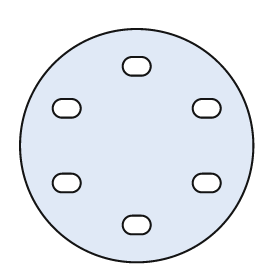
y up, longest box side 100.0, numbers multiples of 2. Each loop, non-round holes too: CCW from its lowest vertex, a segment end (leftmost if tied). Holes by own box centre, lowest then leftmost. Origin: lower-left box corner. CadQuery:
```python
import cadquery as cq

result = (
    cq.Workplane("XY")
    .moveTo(50.0, 50.0)
    .circle(50.0)
    .moveTo(48.0, 12.0)
    .lineTo(52.0, 12.0)
    .threePointArc((56.0, 16.0), (52.0, 20.0))
    .lineTo(48.0, 20.0)
    .threePointArc((44.0, 16.0), (48.0, 12.0))
    .close()
    .moveTo(18.0, 30.0)
    .lineTo(22.0, 30.0)
    .threePointArc((26.0, 34.0), (22.0, 38.0))
    .lineTo(18.0, 38.0)
    .threePointArc((14.0, 34.0), (18.0, 30.0))
    .close()
    .moveTo(78.0, 30.0)
    .lineTo(82.0, 30.0)
    .threePointArc((86.0, 34.0), (82.0, 38.0))
    .lineTo(78.0, 38.0)
    .threePointArc((74.0, 34.0), (78.0, 30.0))
    .close()
    .moveTo(18.0, 62.0)
    .lineTo(22.0, 62.0)
    .threePointArc((26.0, 66.0), (22.0, 70.0))
    .lineTo(18.0, 70.0)
    .threePointArc((14.0, 66.0), (18.0, 62.0))
    .close()
    .moveTo(78.0, 62.0)
    .lineTo(82.0, 62.0)
    .threePointArc((86.0, 66.0), (82.0, 70.0))
    .lineTo(78.0, 70.0)
    .threePointArc((74.0, 66.0), (78.0, 62.0))
    .close()
    .moveTo(48.0, 80.0)
    .lineTo(52.0, 80.0)
    .threePointArc((56.0, 84.0), (52.0, 88.0))
    .lineTo(48.0, 88.0)
    .threePointArc((44.0, 84.0), (48.0, 80.0))
    .close()
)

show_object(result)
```